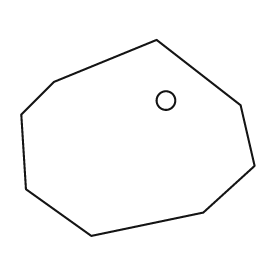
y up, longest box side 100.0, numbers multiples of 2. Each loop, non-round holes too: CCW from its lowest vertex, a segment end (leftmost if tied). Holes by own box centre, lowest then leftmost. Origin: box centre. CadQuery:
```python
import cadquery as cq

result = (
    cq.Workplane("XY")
    .moveTo(-20.0, -42.0)
    .lineTo(28.0, -32.0)
    .lineTo(50.0, -12.0)
    .lineTo(44.0, 14.0)
    .lineTo(8.0, 42.0)
    .lineTo(-36.0, 24.0)
    .lineTo(-50.0, 10.0)
    .lineTo(-48.0, -22.0)
    .close()
    .moveTo(12.0, 16.0)
    .circle(4.0)
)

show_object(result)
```